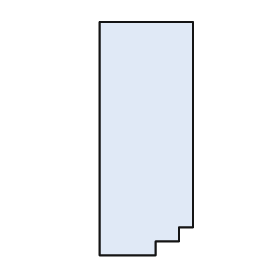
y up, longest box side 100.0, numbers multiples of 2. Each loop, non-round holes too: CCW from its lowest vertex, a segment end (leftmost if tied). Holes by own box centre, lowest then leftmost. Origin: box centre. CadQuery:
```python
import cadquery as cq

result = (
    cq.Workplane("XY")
    .moveTo(-20.0, -50.0)
    .lineTo(4.0, -50.0)
    .lineTo(4.0, -44.0)
    .lineTo(14.0, -44.0)
    .lineTo(14.0, -38.0)
    .lineTo(20.0, -38.0)
    .lineTo(20.0, 50.0)
    .lineTo(-20.0, 50.0)
    .close()
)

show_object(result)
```